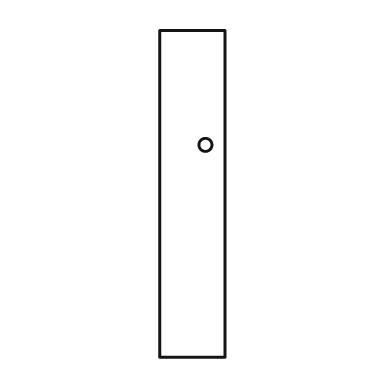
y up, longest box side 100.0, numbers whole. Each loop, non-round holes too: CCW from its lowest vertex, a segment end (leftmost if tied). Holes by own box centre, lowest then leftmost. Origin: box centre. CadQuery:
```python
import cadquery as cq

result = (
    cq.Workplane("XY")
    .moveTo(-10.0, -50.0)
    .lineTo(10.0, -50.0)
    .lineTo(10.0, 50.0)
    .lineTo(-10.0, 50.0)
    .close()
    .moveTo(4.0, 15.0)
    .circle(2.0)
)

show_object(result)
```